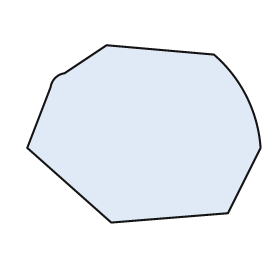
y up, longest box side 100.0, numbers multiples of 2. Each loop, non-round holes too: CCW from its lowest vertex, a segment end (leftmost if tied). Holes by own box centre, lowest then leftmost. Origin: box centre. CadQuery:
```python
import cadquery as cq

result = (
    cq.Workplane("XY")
    .moveTo(-14.0, -38.0)
    .lineTo(36.0, -34.0)
    .lineTo(50.0, -6.0)
    .threePointArc((44.0, 16.0), (30.0, 34.0))
    .lineTo(-16.0, 38.0)
    .lineTo(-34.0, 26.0)
    .threePointArc((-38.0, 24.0), (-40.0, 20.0))
    .lineTo(-50.0, -6.0)
    .close()
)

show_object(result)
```